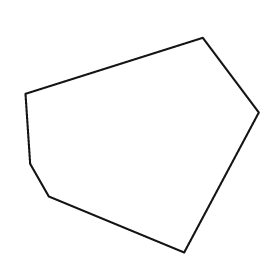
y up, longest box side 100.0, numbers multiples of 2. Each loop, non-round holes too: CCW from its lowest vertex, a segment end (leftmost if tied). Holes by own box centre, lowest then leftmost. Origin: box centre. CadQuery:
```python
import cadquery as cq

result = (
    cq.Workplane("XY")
    .moveTo(18.0, -46.0)
    .lineTo(50.0, 14.0)
    .lineTo(26.0, 46.0)
    .lineTo(-50.0, 22.0)
    .lineTo(-48.0, -8.0)
    .lineTo(-40.0, -22.0)
    .close()
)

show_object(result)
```